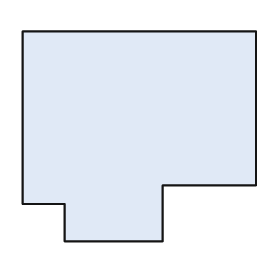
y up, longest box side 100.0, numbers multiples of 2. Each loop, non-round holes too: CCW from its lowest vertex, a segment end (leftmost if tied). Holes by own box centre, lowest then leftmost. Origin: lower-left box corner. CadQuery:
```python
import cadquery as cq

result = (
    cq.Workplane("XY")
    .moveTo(18.0, 0.0)
    .lineTo(60.0, 0.0)
    .lineTo(60.0, 24.0)
    .lineTo(100.0, 24.0)
    .lineTo(100.0, 90.0)
    .lineTo(0.0, 90.0)
    .lineTo(0.0, 16.0)
    .lineTo(18.0, 16.0)
    .close()
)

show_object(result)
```